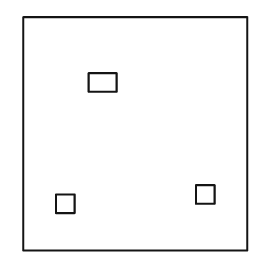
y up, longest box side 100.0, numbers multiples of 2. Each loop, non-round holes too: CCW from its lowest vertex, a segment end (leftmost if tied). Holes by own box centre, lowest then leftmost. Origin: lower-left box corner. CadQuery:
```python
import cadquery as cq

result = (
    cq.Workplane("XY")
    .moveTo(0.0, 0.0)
    .lineTo(96.0, 0.0)
    .lineTo(96.0, 100.0)
    .lineTo(0.0, 100.0)
    .close()
    .moveTo(14.0, 16.0)
    .lineTo(22.0, 16.0)
    .lineTo(22.0, 24.0)
    .lineTo(14.0, 24.0)
    .close()
    .moveTo(74.0, 20.0)
    .lineTo(82.0, 20.0)
    .lineTo(82.0, 28.0)
    .lineTo(74.0, 28.0)
    .close()
    .moveTo(28.0, 68.0)
    .lineTo(40.0, 68.0)
    .lineTo(40.0, 76.0)
    .lineTo(28.0, 76.0)
    .close()
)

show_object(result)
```